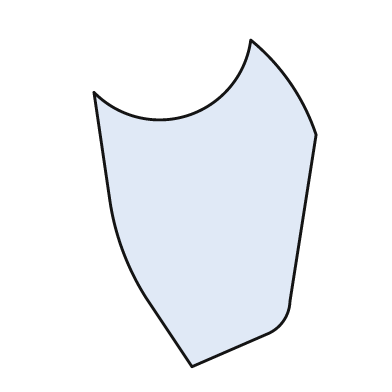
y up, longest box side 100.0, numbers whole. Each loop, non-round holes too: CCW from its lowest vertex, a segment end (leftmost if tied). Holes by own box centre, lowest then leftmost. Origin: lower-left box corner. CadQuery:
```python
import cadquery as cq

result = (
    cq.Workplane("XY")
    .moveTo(30.0, 0.0)
    .lineTo(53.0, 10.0)
    .threePointArc((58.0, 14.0), (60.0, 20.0))
    .lineTo(68.0, 71.0)
    .threePointArc((60.0, 87.0), (48.0, 100.0))
    .threePointArc((29.0, 77.0), (0.0, 84.0))
    .lineTo(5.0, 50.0)
    .threePointArc((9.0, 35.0), (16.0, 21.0))
    .close()
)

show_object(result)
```